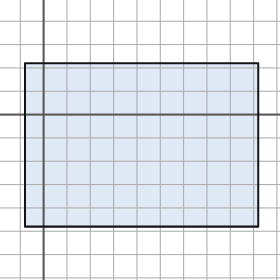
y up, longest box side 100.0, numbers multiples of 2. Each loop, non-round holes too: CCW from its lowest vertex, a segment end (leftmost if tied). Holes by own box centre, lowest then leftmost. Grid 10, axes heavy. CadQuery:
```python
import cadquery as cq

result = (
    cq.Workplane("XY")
    .moveTo(-8.0, -48.0)
    .lineTo(92.0, -48.0)
    .lineTo(92.0, 22.0)
    .lineTo(-8.0, 22.0)
    .close()
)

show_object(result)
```